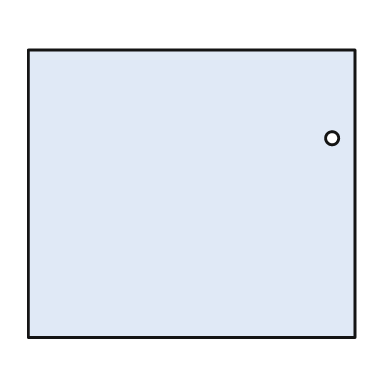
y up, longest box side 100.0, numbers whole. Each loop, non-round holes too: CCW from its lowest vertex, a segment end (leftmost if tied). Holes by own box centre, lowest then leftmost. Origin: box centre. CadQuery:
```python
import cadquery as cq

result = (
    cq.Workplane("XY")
    .moveTo(-50.0, -44.0)
    .lineTo(50.0, -44.0)
    .lineTo(50.0, 44.0)
    .lineTo(-50.0, 44.0)
    .close()
    .moveTo(43.0, 17.0)
    .circle(2.0)
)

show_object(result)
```